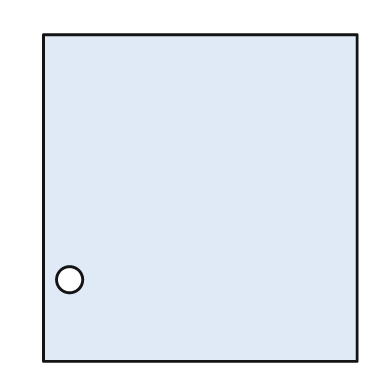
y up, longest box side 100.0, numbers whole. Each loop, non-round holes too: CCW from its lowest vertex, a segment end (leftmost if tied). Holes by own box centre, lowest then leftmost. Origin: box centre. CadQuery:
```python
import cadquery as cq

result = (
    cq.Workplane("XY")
    .moveTo(-48.0, -50.0)
    .lineTo(48.0, -50.0)
    .lineTo(48.0, 50.0)
    .lineTo(-48.0, 50.0)
    .close()
    .moveTo(-40.0, -25.0)
    .circle(4.0)
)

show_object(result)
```